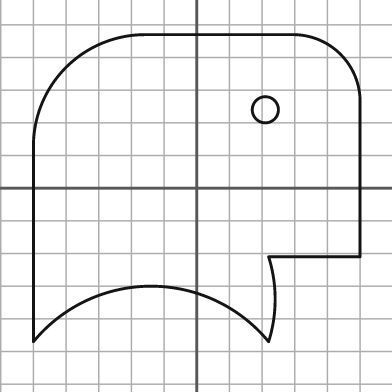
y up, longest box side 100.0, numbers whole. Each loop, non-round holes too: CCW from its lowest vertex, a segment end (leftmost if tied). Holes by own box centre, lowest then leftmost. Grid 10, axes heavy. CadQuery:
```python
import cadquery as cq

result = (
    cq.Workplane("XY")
    .moveTo(-50.0, -47.0)
    .threePointArc((-14.0, -30.0), (22.0, -47.0))
    .threePointArc((24.0, -34.0), (22.0, -21.0))
    .lineTo(50.0, -21.0)
    .lineTo(50.0, 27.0)
    .threePointArc((44.0, 41.0), (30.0, 47.0))
    .lineTo(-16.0, 47.0)
    .threePointArc((-40.0, 37.0), (-50.0, 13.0))
    .close()
    .moveTo(21.0, 24.0)
    .circle(4.0)
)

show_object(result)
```